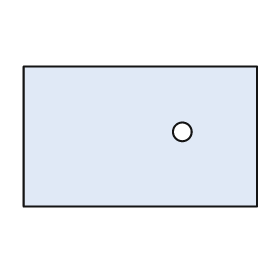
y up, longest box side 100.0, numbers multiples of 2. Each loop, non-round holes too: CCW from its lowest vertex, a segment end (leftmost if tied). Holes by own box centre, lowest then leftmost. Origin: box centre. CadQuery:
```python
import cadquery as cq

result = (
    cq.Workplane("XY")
    .moveTo(-50.0, -30.0)
    .lineTo(50.0, -30.0)
    .lineTo(50.0, 30.0)
    .lineTo(-50.0, 30.0)
    .close()
    .moveTo(18.0, 2.0)
    .circle(4.0)
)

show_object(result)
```